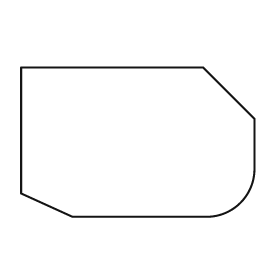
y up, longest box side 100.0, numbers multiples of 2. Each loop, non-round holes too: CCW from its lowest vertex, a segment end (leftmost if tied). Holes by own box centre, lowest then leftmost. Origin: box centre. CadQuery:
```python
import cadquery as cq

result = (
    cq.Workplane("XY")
    .moveTo(-28.0, -32.0)
    .lineTo(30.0, -32.0)
    .threePointArc((44.0, -26.0), (50.0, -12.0))
    .lineTo(50.0, 10.0)
    .lineTo(28.0, 32.0)
    .lineTo(-50.0, 32.0)
    .lineTo(-50.0, -22.0)
    .close()
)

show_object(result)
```